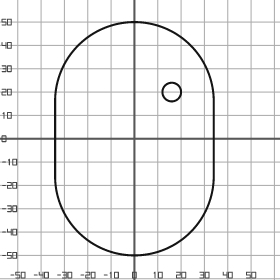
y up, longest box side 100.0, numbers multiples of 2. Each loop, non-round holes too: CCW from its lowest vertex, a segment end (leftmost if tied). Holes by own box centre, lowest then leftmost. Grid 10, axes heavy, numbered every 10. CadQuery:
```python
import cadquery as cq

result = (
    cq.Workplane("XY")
    .moveTo(-34.0, -16.0)
    .threePointArc((0.0, -50.0), (34.0, -16.0))
    .lineTo(34.0, 16.0)
    .threePointArc((0.0, 50.0), (-34.0, 16.0))
    .close()
    .moveTo(16.0, 20.0)
    .circle(4.0)
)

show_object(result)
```